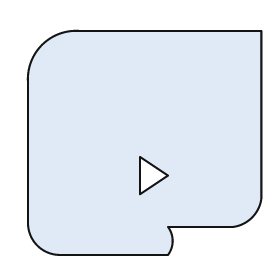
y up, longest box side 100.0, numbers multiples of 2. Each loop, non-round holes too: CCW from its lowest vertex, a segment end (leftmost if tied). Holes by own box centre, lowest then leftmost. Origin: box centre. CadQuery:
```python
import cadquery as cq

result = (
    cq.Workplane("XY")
    .moveTo(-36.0, -48.0)
    .lineTo(10.0, -48.0)
    .threePointArc((12.0, -42.0), (10.0, -36.0))
    .lineTo(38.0, -36.0)
    .threePointArc((46.0, -32.0), (50.0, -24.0))
    .lineTo(50.0, 48.0)
    .lineTo(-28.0, 48.0)
    .threePointArc((-44.0, 42.0), (-50.0, 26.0))
    .lineTo(-50.0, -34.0)
    .threePointArc((-46.0, -44.0), (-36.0, -48.0))
    .close()
    .moveTo(-2.0, -22.0)
    .lineTo(10.0, -14.0)
    .lineTo(-2.0, -6.0)
    .close()
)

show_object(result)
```